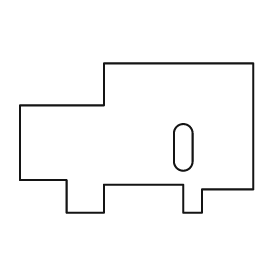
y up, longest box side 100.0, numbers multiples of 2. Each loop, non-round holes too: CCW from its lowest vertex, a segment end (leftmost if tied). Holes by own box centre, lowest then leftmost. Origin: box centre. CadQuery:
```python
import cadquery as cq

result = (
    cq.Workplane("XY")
    .moveTo(-30.0, -32.0)
    .lineTo(-14.0, -32.0)
    .lineTo(-14.0, -20.0)
    .lineTo(20.0, -20.0)
    .lineTo(20.0, -32.0)
    .lineTo(28.0, -32.0)
    .lineTo(28.0, -22.0)
    .lineTo(50.0, -22.0)
    .lineTo(50.0, 32.0)
    .lineTo(-14.0, 32.0)
    .lineTo(-14.0, 14.0)
    .lineTo(-50.0, 14.0)
    .lineTo(-50.0, -18.0)
    .lineTo(-30.0, -18.0)
    .close()
    .moveTo(16.0, -10.0)
    .threePointArc((20.0, -14.0), (24.0, -10.0))
    .lineTo(24.0, 2.0)
    .threePointArc((20.0, 6.0), (16.0, 2.0))
    .close()
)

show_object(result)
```